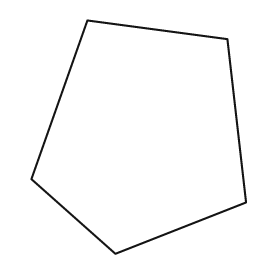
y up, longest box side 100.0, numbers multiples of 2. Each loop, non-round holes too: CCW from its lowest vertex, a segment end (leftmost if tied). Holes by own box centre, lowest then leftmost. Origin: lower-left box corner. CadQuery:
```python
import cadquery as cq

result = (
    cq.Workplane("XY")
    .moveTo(36.0, 0.0)
    .lineTo(92.0, 22.0)
    .lineTo(84.0, 92.0)
    .lineTo(24.0, 100.0)
    .lineTo(0.0, 32.0)
    .close()
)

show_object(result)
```